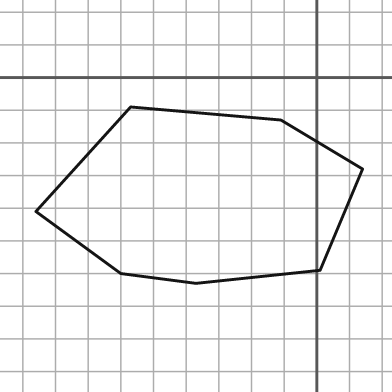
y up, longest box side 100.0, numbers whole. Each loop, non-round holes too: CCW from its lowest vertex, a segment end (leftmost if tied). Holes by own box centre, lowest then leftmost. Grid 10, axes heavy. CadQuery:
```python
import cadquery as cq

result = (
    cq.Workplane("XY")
    .moveTo(-37.0, -63.0)
    .lineTo(1.0, -59.0)
    .lineTo(14.0, -28.0)
    .lineTo(-11.0, -13.0)
    .lineTo(-57.0, -9.0)
    .lineTo(-86.0, -41.0)
    .lineTo(-60.0, -60.0)
    .close()
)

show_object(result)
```